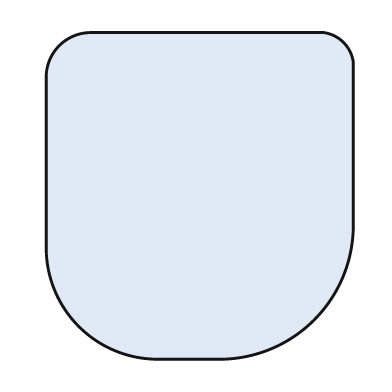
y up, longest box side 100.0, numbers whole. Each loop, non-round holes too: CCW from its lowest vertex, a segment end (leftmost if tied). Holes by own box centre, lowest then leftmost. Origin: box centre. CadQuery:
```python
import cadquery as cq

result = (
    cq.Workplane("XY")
    .moveTo(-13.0, -50.0)
    .lineTo(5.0, -50.0)
    .threePointArc((35.0, -38.0), (47.0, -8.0))
    .lineTo(47.0, 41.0)
    .threePointArc((44.0, 47.0), (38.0, 50.0))
    .lineTo(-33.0, 50.0)
    .threePointArc((-43.0, 46.0), (-47.0, 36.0))
    .lineTo(-47.0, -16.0)
    .threePointArc((-37.0, -40.0), (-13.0, -50.0))
    .close()
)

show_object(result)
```